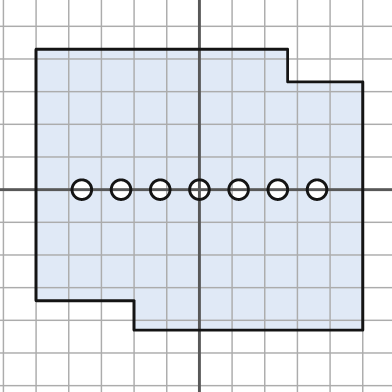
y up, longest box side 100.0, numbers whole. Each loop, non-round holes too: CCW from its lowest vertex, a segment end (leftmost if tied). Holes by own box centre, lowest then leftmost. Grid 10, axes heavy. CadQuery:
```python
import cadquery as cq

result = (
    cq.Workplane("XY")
    .moveTo(-20.0, -43.0)
    .lineTo(50.0, -43.0)
    .lineTo(50.0, 33.0)
    .lineTo(27.0, 33.0)
    .lineTo(27.0, 43.0)
    .lineTo(-50.0, 43.0)
    .lineTo(-50.0, -34.0)
    .lineTo(-20.0, -34.0)
    .close()
    .moveTo(-36.0, 0.0)
    .circle(3.0)
    .moveTo(-24.0, 0.0)
    .circle(3.0)
    .moveTo(-12.0, 0.0)
    .circle(3.0)
    .moveTo(0.0, 0.0)
    .circle(3.0)
    .moveTo(12.0, 0.0)
    .circle(3.0)
    .moveTo(24.0, 0.0)
    .circle(3.0)
    .moveTo(36.0, 0.0)
    .circle(3.0)
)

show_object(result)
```